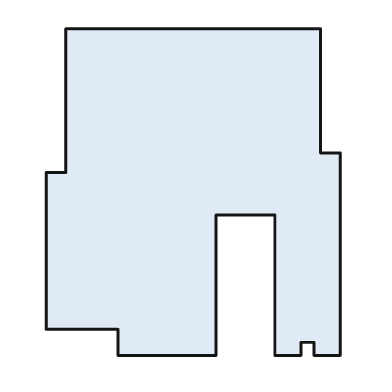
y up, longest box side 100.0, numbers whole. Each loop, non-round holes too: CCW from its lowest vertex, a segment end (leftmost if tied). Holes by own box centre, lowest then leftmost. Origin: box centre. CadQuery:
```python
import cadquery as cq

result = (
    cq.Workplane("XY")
    .moveTo(-23.0, -50.0)
    .lineTo(7.0, -50.0)
    .lineTo(7.0, -7.0)
    .lineTo(25.0, -7.0)
    .lineTo(25.0, -50.0)
    .lineTo(33.0, -50.0)
    .lineTo(33.0, -46.0)
    .lineTo(37.0, -46.0)
    .lineTo(37.0, -50.0)
    .lineTo(45.0, -50.0)
    .lineTo(45.0, 12.0)
    .lineTo(39.0, 12.0)
    .lineTo(39.0, 50.0)
    .lineTo(-39.0, 50.0)
    .lineTo(-39.0, 6.0)
    .lineTo(-45.0, 6.0)
    .lineTo(-45.0, -42.0)
    .lineTo(-23.0, -42.0)
    .close()
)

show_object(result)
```